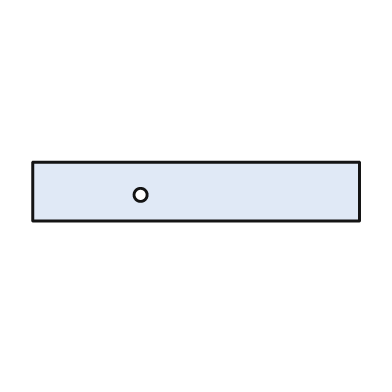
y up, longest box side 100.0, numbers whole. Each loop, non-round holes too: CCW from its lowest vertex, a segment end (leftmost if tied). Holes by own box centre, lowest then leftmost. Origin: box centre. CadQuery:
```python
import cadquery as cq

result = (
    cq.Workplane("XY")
    .moveTo(-50.0, -9.0)
    .lineTo(50.0, -9.0)
    .lineTo(50.0, 9.0)
    .lineTo(-50.0, 9.0)
    .close()
    .moveTo(-17.0, -1.0)
    .circle(2.0)
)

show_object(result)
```